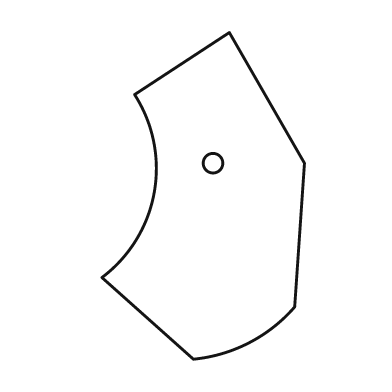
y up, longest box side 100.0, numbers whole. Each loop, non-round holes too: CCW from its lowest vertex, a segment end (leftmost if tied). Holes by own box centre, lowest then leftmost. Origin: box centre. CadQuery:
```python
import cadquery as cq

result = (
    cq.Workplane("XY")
    .moveTo(-3.0, -50.0)
    .threePointArc((14.0, -45.0), (28.0, -34.0))
    .lineTo(31.0, 10.0)
    .lineTo(8.0, 50.0)
    .lineTo(-21.0, 31.0)
    .threePointArc((-15.0, 1.0), (-31.0, -25.0))
    .close()
    .moveTo(3.0, 10.0)
    .circle(3.0)
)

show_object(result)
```